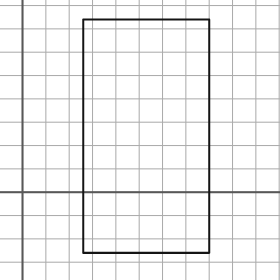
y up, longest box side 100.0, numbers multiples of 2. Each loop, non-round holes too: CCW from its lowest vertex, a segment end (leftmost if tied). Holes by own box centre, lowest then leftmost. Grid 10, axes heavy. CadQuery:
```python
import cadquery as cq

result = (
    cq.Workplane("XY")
    .moveTo(26.0, -26.0)
    .lineTo(80.0, -26.0)
    .lineTo(80.0, 74.0)
    .lineTo(26.0, 74.0)
    .close()
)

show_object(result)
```